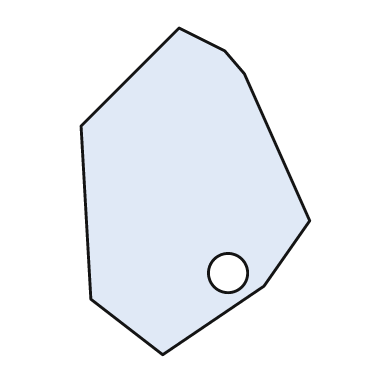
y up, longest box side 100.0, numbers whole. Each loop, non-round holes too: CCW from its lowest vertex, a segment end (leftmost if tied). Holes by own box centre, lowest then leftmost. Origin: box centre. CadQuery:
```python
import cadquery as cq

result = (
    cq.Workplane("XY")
    .moveTo(-10.0, -50.0)
    .lineTo(21.0, -29.0)
    .lineTo(35.0, -9.0)
    .lineTo(15.0, 36.0)
    .lineTo(9.0, 43.0)
    .lineTo(-5.0, 50.0)
    .lineTo(-35.0, 20.0)
    .lineTo(-32.0, -33.0)
    .close()
    .moveTo(10.0, -25.0)
    .circle(6.0)
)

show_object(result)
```